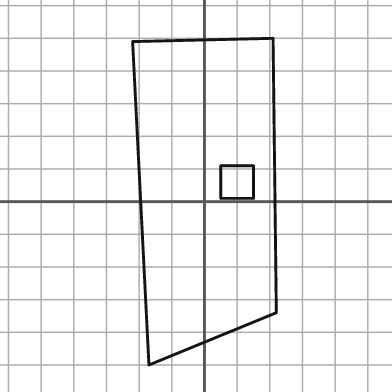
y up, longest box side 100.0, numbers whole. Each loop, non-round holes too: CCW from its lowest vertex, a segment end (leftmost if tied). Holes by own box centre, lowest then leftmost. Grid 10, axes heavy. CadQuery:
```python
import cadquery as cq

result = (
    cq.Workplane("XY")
    .moveTo(-17.0, -50.0)
    .lineTo(22.0, -34.0)
    .lineTo(21.0, 50.0)
    .lineTo(-22.0, 49.0)
    .close()
    .moveTo(5.0, 1.0)
    .lineTo(15.0, 1.0)
    .lineTo(15.0, 11.0)
    .lineTo(5.0, 11.0)
    .close()
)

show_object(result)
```